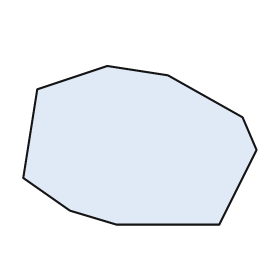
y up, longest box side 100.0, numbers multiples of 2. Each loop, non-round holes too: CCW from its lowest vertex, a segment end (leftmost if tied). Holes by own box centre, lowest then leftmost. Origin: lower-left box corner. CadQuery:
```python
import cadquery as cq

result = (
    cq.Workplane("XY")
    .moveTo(40.0, 0.0)
    .lineTo(84.0, 0.0)
    .lineTo(100.0, 32.0)
    .lineTo(94.0, 46.0)
    .lineTo(62.0, 64.0)
    .lineTo(36.0, 68.0)
    .lineTo(6.0, 58.0)
    .lineTo(0.0, 20.0)
    .lineTo(20.0, 6.0)
    .close()
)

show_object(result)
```